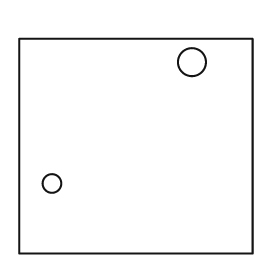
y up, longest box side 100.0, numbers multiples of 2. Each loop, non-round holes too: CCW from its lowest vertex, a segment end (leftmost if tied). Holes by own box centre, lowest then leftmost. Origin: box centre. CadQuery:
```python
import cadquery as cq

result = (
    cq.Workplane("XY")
    .moveTo(-50.0, -46.0)
    .lineTo(50.0, -46.0)
    .lineTo(50.0, 46.0)
    .lineTo(-50.0, 46.0)
    .close()
    .moveTo(-36.0, -16.0)
    .circle(4.0)
    .moveTo(24.0, 36.0)
    .circle(6.0)
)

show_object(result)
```